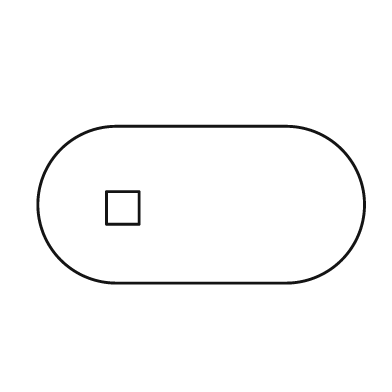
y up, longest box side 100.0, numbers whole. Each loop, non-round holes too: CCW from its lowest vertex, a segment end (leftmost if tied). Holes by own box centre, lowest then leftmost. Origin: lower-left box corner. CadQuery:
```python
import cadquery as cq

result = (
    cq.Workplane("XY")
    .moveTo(24.0, 0.0)
    .lineTo(76.0, 0.0)
    .threePointArc((100.0, 24.0), (76.0, 48.0))
    .lineTo(24.0, 48.0)
    .threePointArc((0.0, 24.0), (24.0, 0.0))
    .close()
    .moveTo(21.0, 18.0)
    .lineTo(31.0, 18.0)
    .lineTo(31.0, 28.0)
    .lineTo(21.0, 28.0)
    .close()
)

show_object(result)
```